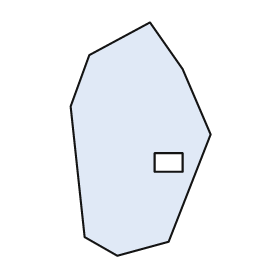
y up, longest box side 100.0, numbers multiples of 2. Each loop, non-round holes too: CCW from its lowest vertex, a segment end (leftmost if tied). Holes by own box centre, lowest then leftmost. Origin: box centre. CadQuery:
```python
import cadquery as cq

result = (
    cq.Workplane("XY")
    .moveTo(-10.0, -50.0)
    .lineTo(12.0, -44.0)
    .lineTo(30.0, 2.0)
    .lineTo(18.0, 30.0)
    .lineTo(4.0, 50.0)
    .lineTo(-22.0, 36.0)
    .lineTo(-30.0, 14.0)
    .lineTo(-24.0, -42.0)
    .close()
    .moveTo(6.0, -14.0)
    .lineTo(18.0, -14.0)
    .lineTo(18.0, -6.0)
    .lineTo(6.0, -6.0)
    .close()
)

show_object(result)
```